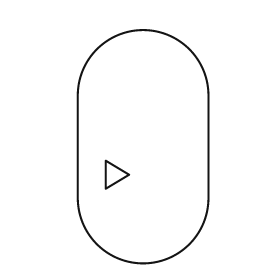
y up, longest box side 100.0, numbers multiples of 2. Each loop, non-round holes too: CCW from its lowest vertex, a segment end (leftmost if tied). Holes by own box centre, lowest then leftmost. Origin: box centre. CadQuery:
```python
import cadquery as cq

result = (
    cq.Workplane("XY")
    .moveTo(-28.0, -22.0)
    .threePointArc((0.0, -50.0), (28.0, -22.0))
    .lineTo(28.0, 22.0)
    .threePointArc((0.0, 50.0), (-28.0, 22.0))
    .close()
    .moveTo(-16.0, -18.0)
    .lineTo(-6.0, -12.0)
    .lineTo(-16.0, -6.0)
    .close()
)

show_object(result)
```